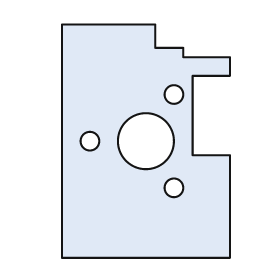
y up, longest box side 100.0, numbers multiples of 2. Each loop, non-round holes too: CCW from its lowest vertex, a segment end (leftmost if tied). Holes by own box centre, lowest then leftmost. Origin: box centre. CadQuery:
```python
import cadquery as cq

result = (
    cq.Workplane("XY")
    .moveTo(-36.0, -50.0)
    .lineTo(36.0, -50.0)
    .lineTo(36.0, -6.0)
    .lineTo(20.0, -6.0)
    .lineTo(20.0, 28.0)
    .lineTo(36.0, 28.0)
    .lineTo(36.0, 36.0)
    .lineTo(16.0, 36.0)
    .lineTo(16.0, 40.0)
    .lineTo(4.0, 40.0)
    .lineTo(4.0, 50.0)
    .lineTo(-36.0, 50.0)
    .close()
    .moveTo(12.0, -20.0)
    .circle(4.0)
    .moveTo(-24.0, 0.0)
    .circle(4.0)
    .moveTo(0.0, 0.0)
    .circle(12.0)
    .moveTo(12.0, 20.0)
    .circle(4.0)
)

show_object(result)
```